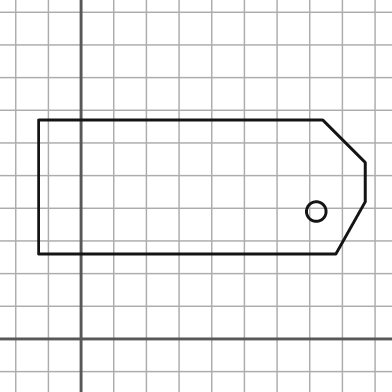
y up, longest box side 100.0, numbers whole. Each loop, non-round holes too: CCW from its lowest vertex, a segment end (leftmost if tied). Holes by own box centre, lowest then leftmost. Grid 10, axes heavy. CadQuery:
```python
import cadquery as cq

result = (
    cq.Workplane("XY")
    .moveTo(-13.0, 26.0)
    .lineTo(78.0, 26.0)
    .lineTo(87.0, 42.0)
    .lineTo(87.0, 54.0)
    .lineTo(74.0, 67.0)
    .lineTo(-13.0, 67.0)
    .close()
    .moveTo(72.0, 39.0)
    .circle(3.0)
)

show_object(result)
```